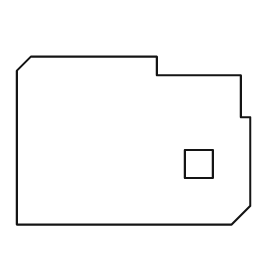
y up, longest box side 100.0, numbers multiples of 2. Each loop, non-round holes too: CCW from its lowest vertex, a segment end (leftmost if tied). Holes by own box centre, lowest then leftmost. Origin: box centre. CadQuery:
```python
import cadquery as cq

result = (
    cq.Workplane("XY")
    .moveTo(-50.0, -36.0)
    .lineTo(42.0, -36.0)
    .lineTo(50.0, -28.0)
    .lineTo(50.0, 10.0)
    .lineTo(46.0, 10.0)
    .lineTo(46.0, 28.0)
    .lineTo(10.0, 28.0)
    .lineTo(10.0, 36.0)
    .lineTo(-44.0, 36.0)
    .lineTo(-50.0, 30.0)
    .close()
    .moveTo(22.0, -16.0)
    .lineTo(34.0, -16.0)
    .lineTo(34.0, -4.0)
    .lineTo(22.0, -4.0)
    .close()
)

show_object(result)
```